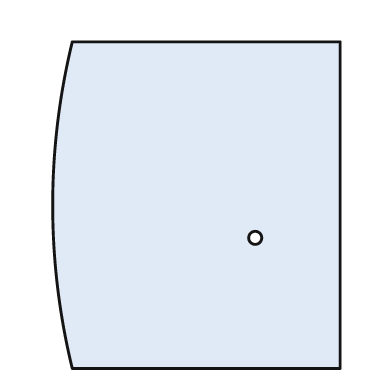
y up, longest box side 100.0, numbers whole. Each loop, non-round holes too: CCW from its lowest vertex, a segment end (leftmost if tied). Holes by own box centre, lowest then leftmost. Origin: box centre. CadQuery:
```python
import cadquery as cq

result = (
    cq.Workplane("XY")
    .moveTo(-38.0, -50.0)
    .lineTo(44.0, -50.0)
    .lineTo(44.0, 50.0)
    .lineTo(-38.0, 50.0)
    .threePointArc((-44.0, 0.0), (-38.0, -50.0))
    .close()
    .moveTo(18.0, -10.0)
    .circle(2.0)
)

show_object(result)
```